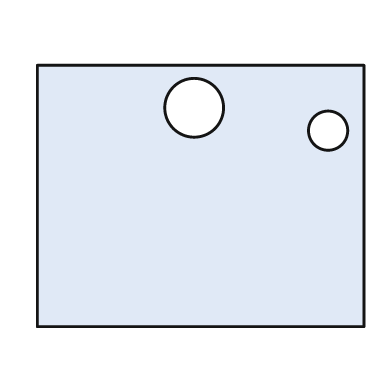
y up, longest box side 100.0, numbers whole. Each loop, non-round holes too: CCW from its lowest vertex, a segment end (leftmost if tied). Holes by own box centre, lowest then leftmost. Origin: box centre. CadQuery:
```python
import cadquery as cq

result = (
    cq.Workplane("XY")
    .moveTo(-50.0, -40.0)
    .lineTo(50.0, -40.0)
    .lineTo(50.0, 40.0)
    .lineTo(-50.0, 40.0)
    .close()
    .moveTo(39.0, 20.0)
    .circle(6.0)
    .moveTo(-2.0, 27.0)
    .circle(9.0)
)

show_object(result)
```